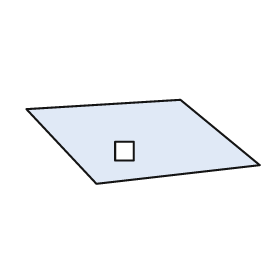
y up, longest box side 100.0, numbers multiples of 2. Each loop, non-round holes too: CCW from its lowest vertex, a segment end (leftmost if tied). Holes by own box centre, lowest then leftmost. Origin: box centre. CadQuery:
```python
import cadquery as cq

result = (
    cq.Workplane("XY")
    .moveTo(-20.0, -18.0)
    .lineTo(50.0, -10.0)
    .lineTo(16.0, 18.0)
    .lineTo(-50.0, 14.0)
    .close()
    .moveTo(-12.0, -8.0)
    .lineTo(-4.0, -8.0)
    .lineTo(-4.0, 0.0)
    .lineTo(-12.0, 0.0)
    .close()
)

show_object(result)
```